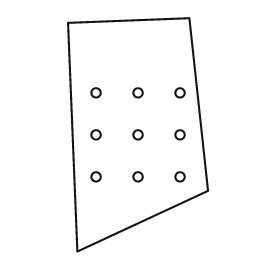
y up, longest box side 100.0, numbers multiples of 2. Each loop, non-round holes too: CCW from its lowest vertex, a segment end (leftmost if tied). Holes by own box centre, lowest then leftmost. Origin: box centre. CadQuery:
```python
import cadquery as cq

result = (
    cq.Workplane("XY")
    .moveTo(-26.0, -50.0)
    .lineTo(30.0, -24.0)
    .lineTo(22.0, 50.0)
    .lineTo(-30.0, 48.0)
    .close()
    .moveTo(-18.0, -18.0)
    .circle(2.0)
    .moveTo(0.0, -18.0)
    .circle(2.0)
    .moveTo(18.0, -18.0)
    .circle(2.0)
    .moveTo(-18.0, 0.0)
    .circle(2.0)
    .moveTo(0.0, 0.0)
    .circle(2.0)
    .moveTo(18.0, 0.0)
    .circle(2.0)
    .moveTo(-18.0, 18.0)
    .circle(2.0)
    .moveTo(0.0, 18.0)
    .circle(2.0)
    .moveTo(18.0, 18.0)
    .circle(2.0)
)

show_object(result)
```